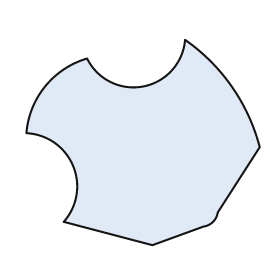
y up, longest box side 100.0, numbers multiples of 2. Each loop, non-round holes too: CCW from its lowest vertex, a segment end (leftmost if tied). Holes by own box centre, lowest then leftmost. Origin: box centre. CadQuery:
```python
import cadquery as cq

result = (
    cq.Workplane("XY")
    .moveTo(4.0, -44.0)
    .lineTo(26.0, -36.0)
    .threePointArc((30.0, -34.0), (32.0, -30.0))
    .lineTo(50.0, -2.0)
    .threePointArc((38.0, 24.0), (18.0, 44.0))
    .threePointArc((0.0, 24.0), (-24.0, 36.0))
    .threePointArc((-42.0, 24.0), (-50.0, 4.0))
    .threePointArc((-30.0, -10.0), (-34.0, -34.0))
    .close()
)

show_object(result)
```